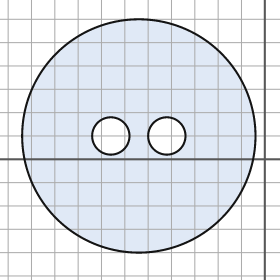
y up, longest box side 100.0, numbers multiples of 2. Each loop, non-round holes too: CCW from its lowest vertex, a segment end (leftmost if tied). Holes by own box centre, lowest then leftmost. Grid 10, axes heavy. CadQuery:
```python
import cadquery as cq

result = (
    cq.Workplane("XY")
    .moveTo(-54.0, 10.0)
    .circle(50.0)
    .moveTo(-66.0, 10.0)
    .circle(8.0)
    .moveTo(-42.0, 10.0)
    .circle(8.0)
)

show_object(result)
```